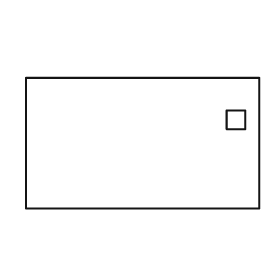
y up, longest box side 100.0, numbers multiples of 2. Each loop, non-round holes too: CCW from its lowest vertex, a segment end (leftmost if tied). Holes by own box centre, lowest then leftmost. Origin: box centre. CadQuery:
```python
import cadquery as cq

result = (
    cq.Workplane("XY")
    .moveTo(-50.0, -28.0)
    .lineTo(50.0, -28.0)
    .lineTo(50.0, 28.0)
    .lineTo(-50.0, 28.0)
    .close()
    .moveTo(36.0, 6.0)
    .lineTo(44.0, 6.0)
    .lineTo(44.0, 14.0)
    .lineTo(36.0, 14.0)
    .close()
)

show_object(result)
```